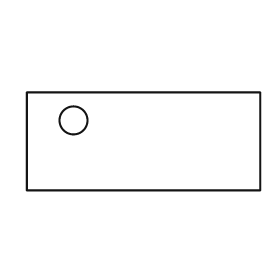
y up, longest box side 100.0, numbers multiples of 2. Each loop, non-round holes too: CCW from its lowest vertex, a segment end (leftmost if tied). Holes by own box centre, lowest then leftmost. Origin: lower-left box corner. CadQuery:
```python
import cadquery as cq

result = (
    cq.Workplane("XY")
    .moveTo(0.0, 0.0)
    .lineTo(100.0, 0.0)
    .lineTo(100.0, 42.0)
    .lineTo(0.0, 42.0)
    .close()
    .moveTo(20.0, 30.0)
    .circle(6.0)
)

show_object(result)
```